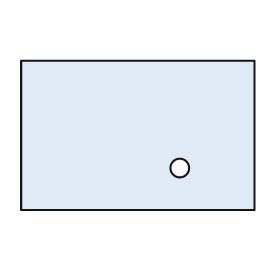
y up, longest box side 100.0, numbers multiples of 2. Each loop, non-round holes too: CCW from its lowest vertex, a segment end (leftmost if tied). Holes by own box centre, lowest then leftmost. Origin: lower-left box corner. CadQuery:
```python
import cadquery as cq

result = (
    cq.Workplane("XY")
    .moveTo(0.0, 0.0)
    .lineTo(100.0, 0.0)
    .lineTo(100.0, 64.0)
    .lineTo(0.0, 64.0)
    .close()
    .moveTo(68.0, 18.0)
    .circle(4.0)
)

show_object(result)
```